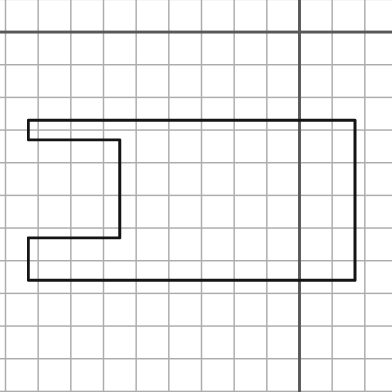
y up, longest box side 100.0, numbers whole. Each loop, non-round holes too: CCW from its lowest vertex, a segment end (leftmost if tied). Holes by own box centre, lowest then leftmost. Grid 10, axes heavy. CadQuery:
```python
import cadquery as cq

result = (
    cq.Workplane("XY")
    .moveTo(-83.0, -76.0)
    .lineTo(17.0, -76.0)
    .lineTo(17.0, -27.0)
    .lineTo(-83.0, -27.0)
    .lineTo(-83.0, -33.0)
    .lineTo(-55.0, -33.0)
    .lineTo(-55.0, -63.0)
    .lineTo(-83.0, -63.0)
    .close()
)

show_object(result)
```